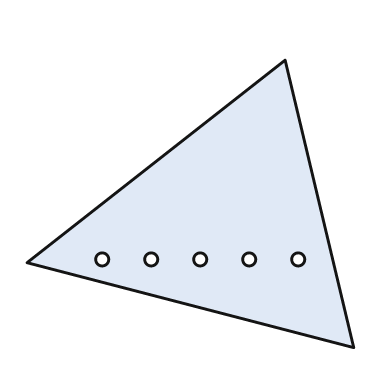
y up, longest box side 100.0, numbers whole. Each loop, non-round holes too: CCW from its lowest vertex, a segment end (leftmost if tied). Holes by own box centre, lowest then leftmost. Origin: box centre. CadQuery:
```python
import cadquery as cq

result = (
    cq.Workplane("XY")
    .moveTo(50.0, -44.0)
    .lineTo(29.0, 44.0)
    .lineTo(-50.0, -18.0)
    .close()
    .moveTo(-27.0, -17.0)
    .circle(2.0)
    .moveTo(-12.0, -17.0)
    .circle(2.0)
    .moveTo(3.0, -17.0)
    .circle(2.0)
    .moveTo(18.0, -17.0)
    .circle(2.0)
    .moveTo(33.0, -17.0)
    .circle(2.0)
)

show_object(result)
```